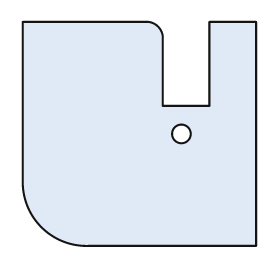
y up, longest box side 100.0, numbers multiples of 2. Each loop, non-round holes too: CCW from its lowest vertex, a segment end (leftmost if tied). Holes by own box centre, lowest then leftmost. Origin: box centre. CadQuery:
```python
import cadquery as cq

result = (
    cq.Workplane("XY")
    .moveTo(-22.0, -48.0)
    .lineTo(50.0, -48.0)
    .lineTo(50.0, 48.0)
    .lineTo(30.0, 48.0)
    .lineTo(30.0, 12.0)
    .lineTo(10.0, 12.0)
    .lineTo(10.0, 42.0)
    .threePointArc((8.0, 46.0), (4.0, 48.0))
    .lineTo(-50.0, 48.0)
    .lineTo(-50.0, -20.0)
    .threePointArc((-42.0, -40.0), (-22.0, -48.0))
    .close()
    .moveTo(18.0, 0.0)
    .circle(4.0)
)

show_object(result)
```